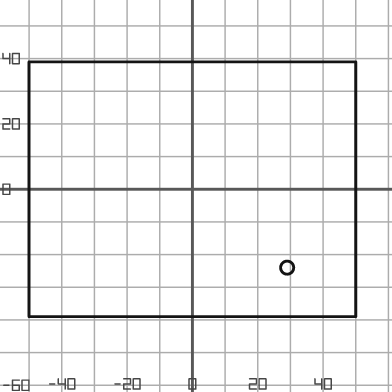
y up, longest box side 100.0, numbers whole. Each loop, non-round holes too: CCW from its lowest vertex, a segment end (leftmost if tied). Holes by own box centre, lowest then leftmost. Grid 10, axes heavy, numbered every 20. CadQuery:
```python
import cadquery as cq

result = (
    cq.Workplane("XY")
    .moveTo(-50.0, -39.0)
    .lineTo(50.0, -39.0)
    .lineTo(50.0, 39.0)
    .lineTo(-50.0, 39.0)
    .close()
    .moveTo(29.0, -24.0)
    .circle(2.0)
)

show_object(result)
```